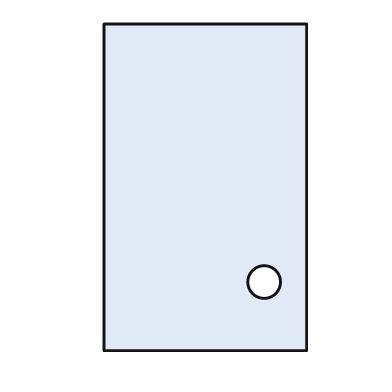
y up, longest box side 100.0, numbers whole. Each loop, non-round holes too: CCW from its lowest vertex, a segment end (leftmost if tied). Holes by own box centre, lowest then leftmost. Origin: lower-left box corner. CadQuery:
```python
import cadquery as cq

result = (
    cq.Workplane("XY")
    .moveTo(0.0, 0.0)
    .lineTo(62.0, 0.0)
    .lineTo(62.0, 100.0)
    .lineTo(0.0, 100.0)
    .close()
    .moveTo(49.0, 21.0)
    .circle(5.0)
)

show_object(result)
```